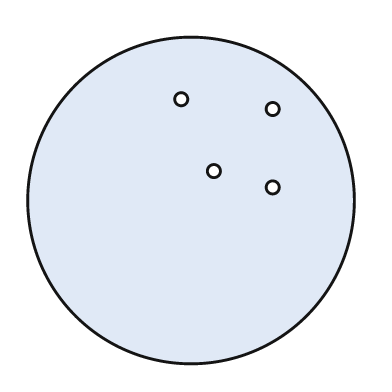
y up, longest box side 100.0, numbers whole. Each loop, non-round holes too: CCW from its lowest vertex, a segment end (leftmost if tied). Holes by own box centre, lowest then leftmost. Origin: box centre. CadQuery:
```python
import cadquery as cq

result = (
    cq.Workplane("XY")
    .moveTo(0.0, 0.0)
    .circle(50.0)
    .moveTo(25.0, 4.0)
    .circle(2.0)
    .moveTo(7.0, 9.0)
    .circle(2.0)
    .moveTo(25.0, 28.0)
    .circle(2.0)
    .moveTo(-3.0, 31.0)
    .circle(2.0)
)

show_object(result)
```